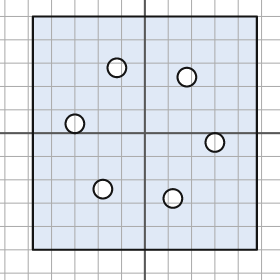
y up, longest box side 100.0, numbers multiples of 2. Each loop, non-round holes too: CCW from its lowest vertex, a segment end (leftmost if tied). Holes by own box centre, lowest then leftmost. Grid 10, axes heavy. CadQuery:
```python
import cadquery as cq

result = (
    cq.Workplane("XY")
    .moveTo(-48.0, -50.0)
    .lineTo(48.0, -50.0)
    .lineTo(48.0, 50.0)
    .lineTo(-48.0, 50.0)
    .close()
    .moveTo(12.0, -28.0)
    .circle(4.0)
    .moveTo(-18.0, -24.0)
    .circle(4.0)
    .moveTo(30.0, -4.0)
    .circle(4.0)
    .moveTo(-30.0, 4.0)
    .circle(4.0)
    .moveTo(18.0, 24.0)
    .circle(4.0)
    .moveTo(-12.0, 28.0)
    .circle(4.0)
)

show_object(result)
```